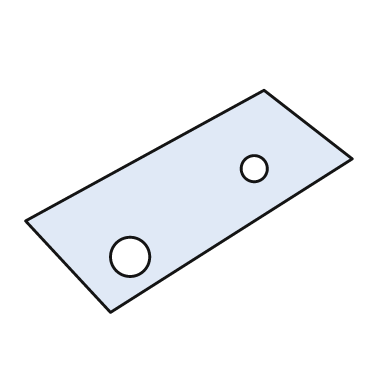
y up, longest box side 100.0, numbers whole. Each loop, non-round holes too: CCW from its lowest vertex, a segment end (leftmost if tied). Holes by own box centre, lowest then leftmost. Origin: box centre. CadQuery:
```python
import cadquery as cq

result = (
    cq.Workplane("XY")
    .moveTo(-24.0, -34.0)
    .lineTo(50.0, 13.0)
    .lineTo(23.0, 34.0)
    .lineTo(-50.0, -6.0)
    .close()
    .moveTo(-18.0, -17.0)
    .circle(6.0)
    .moveTo(20.0, 10.0)
    .circle(4.0)
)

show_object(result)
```